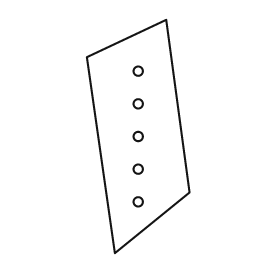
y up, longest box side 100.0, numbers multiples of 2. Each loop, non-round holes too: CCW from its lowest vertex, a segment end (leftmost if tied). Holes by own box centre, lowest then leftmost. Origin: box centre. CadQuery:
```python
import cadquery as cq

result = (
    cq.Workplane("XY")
    .moveTo(-10.0, -50.0)
    .lineTo(22.0, -24.0)
    .lineTo(12.0, 50.0)
    .lineTo(-22.0, 34.0)
    .close()
    .moveTo(0.0, -28.0)
    .circle(2.0)
    .moveTo(0.0, -14.0)
    .circle(2.0)
    .moveTo(0.0, 0.0)
    .circle(2.0)
    .moveTo(0.0, 14.0)
    .circle(2.0)
    .moveTo(0.0, 28.0)
    .circle(2.0)
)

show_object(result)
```